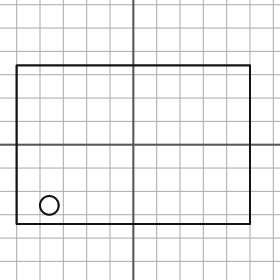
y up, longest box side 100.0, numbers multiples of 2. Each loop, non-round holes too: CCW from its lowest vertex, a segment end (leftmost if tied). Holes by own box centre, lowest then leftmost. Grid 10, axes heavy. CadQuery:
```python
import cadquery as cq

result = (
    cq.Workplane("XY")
    .moveTo(-50.0, -34.0)
    .lineTo(50.0, -34.0)
    .lineTo(50.0, 34.0)
    .lineTo(-50.0, 34.0)
    .close()
    .moveTo(-36.0, -26.0)
    .circle(4.0)
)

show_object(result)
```